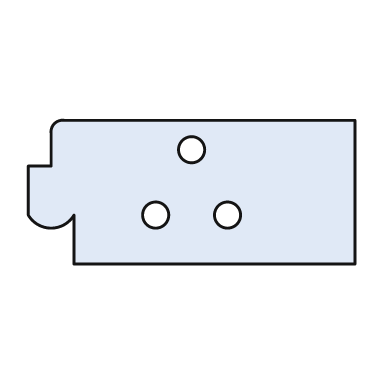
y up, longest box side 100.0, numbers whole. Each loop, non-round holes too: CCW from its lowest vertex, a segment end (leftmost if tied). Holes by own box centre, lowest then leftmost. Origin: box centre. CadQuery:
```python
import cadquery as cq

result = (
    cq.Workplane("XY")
    .moveTo(-36.0, -22.0)
    .lineTo(50.0, -22.0)
    .lineTo(50.0, 22.0)
    .lineTo(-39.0, 22.0)
    .threePointArc((-42.0, 21.0), (-43.0, 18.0))
    .lineTo(-43.0, 8.0)
    .lineTo(-50.0, 8.0)
    .lineTo(-50.0, -7.0)
    .threePointArc((-43.0, -11.0), (-36.0, -7.0))
    .close()
    .moveTo(-11.0, -7.0)
    .circle(4.0)
    .moveTo(11.0, -7.0)
    .circle(4.0)
    .moveTo(0.0, 13.0)
    .circle(4.0)
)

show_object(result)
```